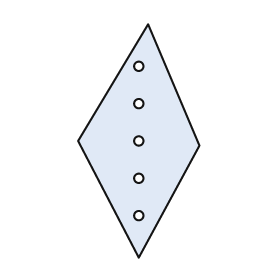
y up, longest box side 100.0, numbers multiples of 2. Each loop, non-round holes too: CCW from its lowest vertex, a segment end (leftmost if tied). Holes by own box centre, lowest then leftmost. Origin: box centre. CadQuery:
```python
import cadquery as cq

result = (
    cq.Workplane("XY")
    .moveTo(0.0, -50.0)
    .lineTo(26.0, -2.0)
    .lineTo(4.0, 50.0)
    .lineTo(-26.0, 0.0)
    .close()
    .moveTo(0.0, -32.0)
    .circle(2.0)
    .moveTo(0.0, -16.0)
    .circle(2.0)
    .moveTo(0.0, 0.0)
    .circle(2.0)
    .moveTo(0.0, 16.0)
    .circle(2.0)
    .moveTo(0.0, 32.0)
    .circle(2.0)
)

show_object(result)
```